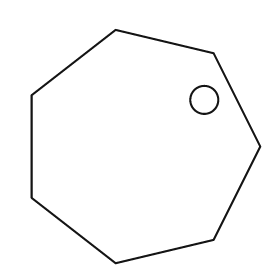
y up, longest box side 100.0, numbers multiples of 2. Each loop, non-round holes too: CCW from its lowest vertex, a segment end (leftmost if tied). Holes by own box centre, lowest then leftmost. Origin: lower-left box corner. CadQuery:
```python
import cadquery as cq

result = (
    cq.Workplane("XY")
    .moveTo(36.0, 0.0)
    .lineTo(78.0, 10.0)
    .lineTo(98.0, 50.0)
    .lineTo(78.0, 90.0)
    .lineTo(36.0, 100.0)
    .lineTo(0.0, 72.0)
    .lineTo(0.0, 28.0)
    .close()
    .moveTo(74.0, 70.0)
    .circle(6.0)
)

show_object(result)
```